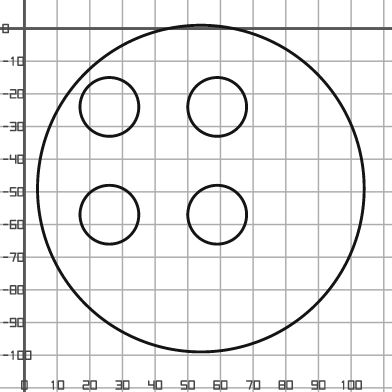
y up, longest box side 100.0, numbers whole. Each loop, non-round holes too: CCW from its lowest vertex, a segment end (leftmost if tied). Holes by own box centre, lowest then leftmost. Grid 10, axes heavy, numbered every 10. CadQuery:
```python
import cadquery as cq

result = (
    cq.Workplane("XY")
    .moveTo(54.0, -49.0)
    .circle(50.0)
    .moveTo(26.0, -57.0)
    .circle(9.0)
    .moveTo(59.0, -57.0)
    .circle(9.0)
    .moveTo(26.0, -24.0)
    .circle(9.0)
    .moveTo(59.0, -24.0)
    .circle(9.0)
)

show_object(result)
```